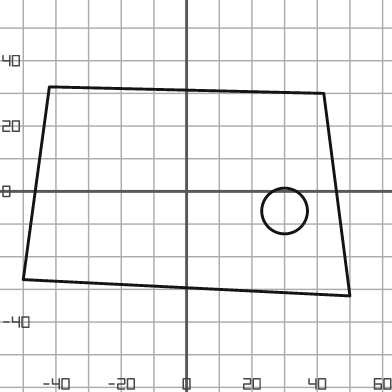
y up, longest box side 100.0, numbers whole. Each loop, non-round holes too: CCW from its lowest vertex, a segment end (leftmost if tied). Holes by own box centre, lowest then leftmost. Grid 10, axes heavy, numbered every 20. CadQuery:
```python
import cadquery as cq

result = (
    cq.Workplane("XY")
    .moveTo(50.0, -32.0)
    .lineTo(42.0, 30.0)
    .lineTo(-42.0, 32.0)
    .lineTo(-50.0, -27.0)
    .close()
    .moveTo(30.0, -6.0)
    .circle(7.0)
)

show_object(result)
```